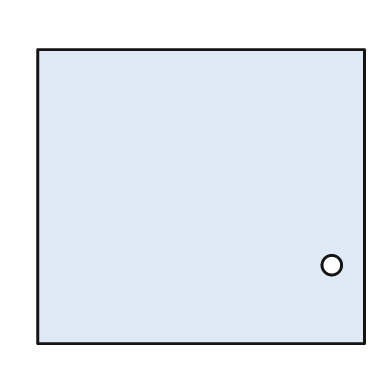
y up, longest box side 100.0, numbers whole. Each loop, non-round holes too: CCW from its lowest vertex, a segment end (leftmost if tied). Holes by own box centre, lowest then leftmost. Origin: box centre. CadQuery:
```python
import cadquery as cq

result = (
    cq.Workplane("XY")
    .moveTo(-50.0, -45.0)
    .lineTo(50.0, -45.0)
    .lineTo(50.0, 45.0)
    .lineTo(-50.0, 45.0)
    .close()
    .moveTo(40.0, -21.0)
    .circle(3.0)
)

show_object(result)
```